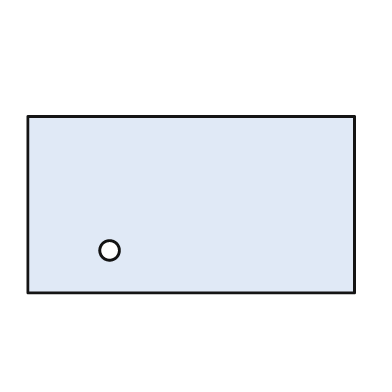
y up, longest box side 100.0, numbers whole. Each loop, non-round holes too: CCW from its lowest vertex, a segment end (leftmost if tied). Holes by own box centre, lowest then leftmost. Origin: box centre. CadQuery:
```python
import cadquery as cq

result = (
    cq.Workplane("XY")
    .moveTo(-50.0, -27.0)
    .lineTo(50.0, -27.0)
    .lineTo(50.0, 27.0)
    .lineTo(-50.0, 27.0)
    .close()
    .moveTo(-25.0, -14.0)
    .circle(3.0)
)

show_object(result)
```